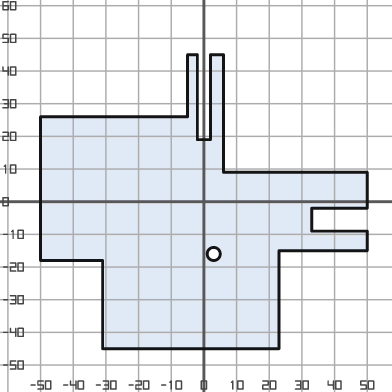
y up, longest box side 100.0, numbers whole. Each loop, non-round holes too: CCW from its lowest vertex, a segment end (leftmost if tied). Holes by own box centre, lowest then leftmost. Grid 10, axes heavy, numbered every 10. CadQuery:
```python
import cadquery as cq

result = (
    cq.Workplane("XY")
    .moveTo(-31.0, -45.0)
    .lineTo(23.0, -45.0)
    .lineTo(23.0, -15.0)
    .lineTo(50.0, -15.0)
    .lineTo(50.0, -9.0)
    .lineTo(33.0, -9.0)
    .lineTo(33.0, -2.0)
    .lineTo(50.0, -2.0)
    .lineTo(50.0, 9.0)
    .lineTo(6.0, 9.0)
    .lineTo(6.0, 45.0)
    .lineTo(2.0, 45.0)
    .lineTo(2.0, 19.0)
    .lineTo(-2.0, 19.0)
    .lineTo(-2.0, 45.0)
    .lineTo(-5.0, 45.0)
    .lineTo(-5.0, 26.0)
    .lineTo(-50.0, 26.0)
    .lineTo(-50.0, -18.0)
    .lineTo(-31.0, -18.0)
    .close()
    .moveTo(3.0, -16.0)
    .circle(2.0)
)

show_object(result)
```